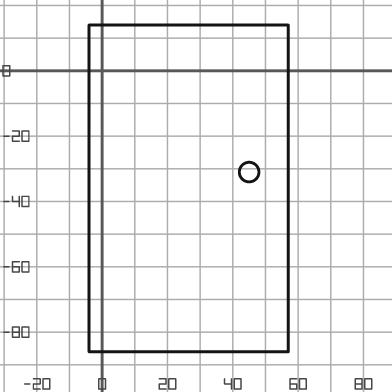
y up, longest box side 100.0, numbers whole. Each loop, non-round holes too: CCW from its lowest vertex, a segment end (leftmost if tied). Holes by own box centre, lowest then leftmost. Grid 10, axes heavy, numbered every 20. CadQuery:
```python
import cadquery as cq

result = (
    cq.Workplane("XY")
    .moveTo(-4.0, -86.0)
    .lineTo(57.0, -86.0)
    .lineTo(57.0, 14.0)
    .lineTo(-4.0, 14.0)
    .close()
    .moveTo(45.0, -31.0)
    .circle(3.0)
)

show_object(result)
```